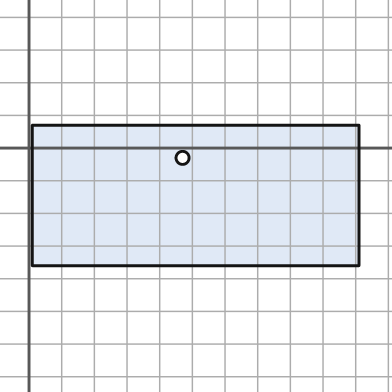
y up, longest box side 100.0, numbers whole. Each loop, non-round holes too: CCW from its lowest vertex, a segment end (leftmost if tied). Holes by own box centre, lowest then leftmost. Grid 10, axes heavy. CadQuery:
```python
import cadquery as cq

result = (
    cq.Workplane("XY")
    .moveTo(1.0, -36.0)
    .lineTo(101.0, -36.0)
    .lineTo(101.0, 7.0)
    .lineTo(1.0, 7.0)
    .close()
    .moveTo(47.0, -3.0)
    .circle(2.0)
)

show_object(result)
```